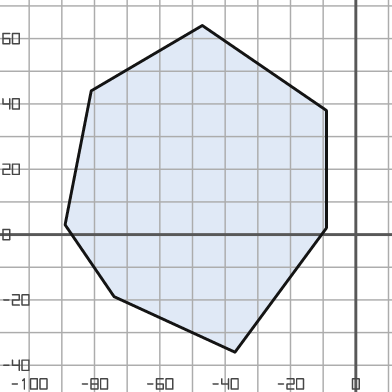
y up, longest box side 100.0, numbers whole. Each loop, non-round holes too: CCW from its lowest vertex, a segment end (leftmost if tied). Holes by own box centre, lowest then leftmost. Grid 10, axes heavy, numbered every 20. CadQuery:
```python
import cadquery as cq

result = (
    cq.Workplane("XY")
    .moveTo(-37.0, -36.0)
    .lineTo(-9.0, 2.0)
    .lineTo(-9.0, 38.0)
    .lineTo(-47.0, 64.0)
    .lineTo(-81.0, 44.0)
    .lineTo(-89.0, 3.0)
    .lineTo(-74.0, -19.0)
    .close()
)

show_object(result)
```